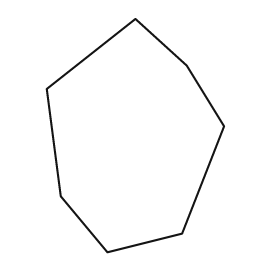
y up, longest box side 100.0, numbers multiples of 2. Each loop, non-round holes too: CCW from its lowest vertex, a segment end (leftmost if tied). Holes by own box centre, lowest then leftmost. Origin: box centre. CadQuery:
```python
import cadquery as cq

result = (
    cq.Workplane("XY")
    .moveTo(-12.0, -50.0)
    .lineTo(20.0, -42.0)
    .lineTo(38.0, 4.0)
    .lineTo(22.0, 30.0)
    .lineTo(0.0, 50.0)
    .lineTo(-38.0, 20.0)
    .lineTo(-32.0, -26.0)
    .close()
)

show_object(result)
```